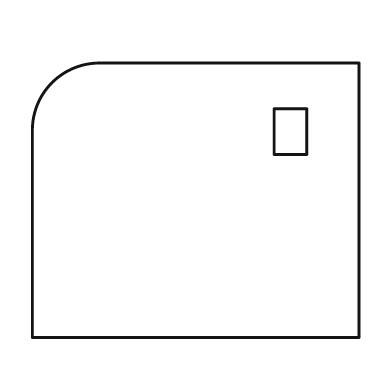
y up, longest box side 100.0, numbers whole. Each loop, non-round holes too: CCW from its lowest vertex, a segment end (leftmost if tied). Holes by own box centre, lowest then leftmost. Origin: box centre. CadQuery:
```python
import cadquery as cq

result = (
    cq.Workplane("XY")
    .moveTo(-50.0, -42.0)
    .lineTo(50.0, -42.0)
    .lineTo(50.0, 42.0)
    .lineTo(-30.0, 42.0)
    .threePointArc((-44.0, 36.0), (-50.0, 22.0))
    .close()
    .moveTo(24.0, 14.0)
    .lineTo(34.0, 14.0)
    .lineTo(34.0, 28.0)
    .lineTo(24.0, 28.0)
    .close()
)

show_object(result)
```